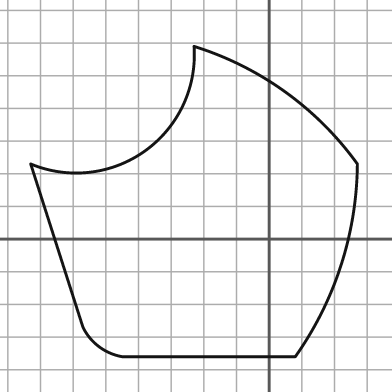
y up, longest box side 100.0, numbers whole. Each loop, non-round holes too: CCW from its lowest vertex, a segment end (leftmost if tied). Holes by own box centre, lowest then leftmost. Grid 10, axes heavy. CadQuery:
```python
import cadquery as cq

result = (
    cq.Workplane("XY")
    .moveTo(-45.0, -36.0)
    .lineTo(8.0, -36.0)
    .threePointArc((22.0, -8.0), (27.0, 23.0))
    .threePointArc((5.0, 45.0), (-23.0, 59.0))
    .threePointArc((-38.0, 27.0), (-73.0, 23.0))
    .lineTo(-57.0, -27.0)
    .threePointArc((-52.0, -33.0), (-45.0, -36.0))
    .close()
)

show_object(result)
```